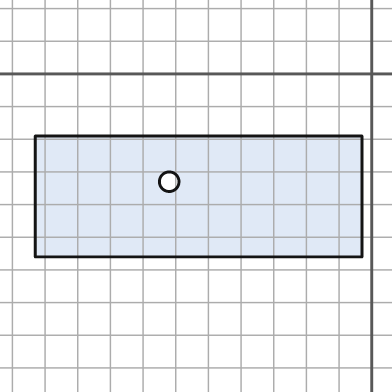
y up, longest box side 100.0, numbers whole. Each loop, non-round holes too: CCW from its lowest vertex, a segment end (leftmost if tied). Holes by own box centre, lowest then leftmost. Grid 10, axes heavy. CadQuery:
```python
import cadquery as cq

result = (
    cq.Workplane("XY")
    .moveTo(-103.0, -56.0)
    .lineTo(-3.0, -56.0)
    .lineTo(-3.0, -19.0)
    .lineTo(-103.0, -19.0)
    .close()
    .moveTo(-62.0, -33.0)
    .circle(3.0)
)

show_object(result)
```